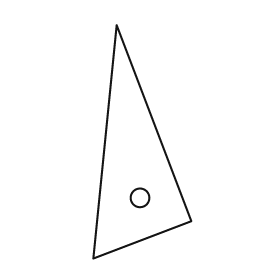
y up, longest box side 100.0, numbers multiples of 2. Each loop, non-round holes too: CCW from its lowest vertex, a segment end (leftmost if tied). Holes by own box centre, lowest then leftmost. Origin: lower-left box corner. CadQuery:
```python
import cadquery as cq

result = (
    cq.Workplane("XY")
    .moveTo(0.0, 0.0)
    .lineTo(42.0, 16.0)
    .lineTo(10.0, 100.0)
    .close()
    .moveTo(20.0, 26.0)
    .circle(4.0)
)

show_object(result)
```